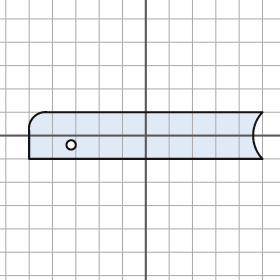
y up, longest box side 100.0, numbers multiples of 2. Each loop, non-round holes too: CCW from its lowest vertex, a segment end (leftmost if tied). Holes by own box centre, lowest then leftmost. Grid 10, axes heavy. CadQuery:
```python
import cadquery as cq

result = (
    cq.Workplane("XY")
    .moveTo(-50.0, -10.0)
    .lineTo(50.0, -10.0)
    .threePointArc((46.0, 0.0), (50.0, 10.0))
    .lineTo(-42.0, 10.0)
    .threePointArc((-48.0, 8.0), (-50.0, 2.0))
    .close()
    .moveTo(-32.0, -4.0)
    .circle(2.0)
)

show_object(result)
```